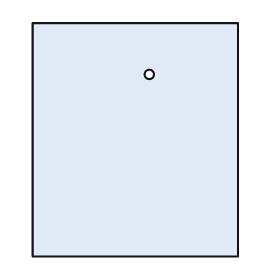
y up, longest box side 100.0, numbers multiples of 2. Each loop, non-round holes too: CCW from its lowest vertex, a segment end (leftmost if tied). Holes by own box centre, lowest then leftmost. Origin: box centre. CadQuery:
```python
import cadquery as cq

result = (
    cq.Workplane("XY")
    .moveTo(-44.0, -50.0)
    .lineTo(44.0, -50.0)
    .lineTo(44.0, 50.0)
    .lineTo(-44.0, 50.0)
    .close()
    .moveTo(6.0, 28.0)
    .circle(2.0)
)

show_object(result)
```